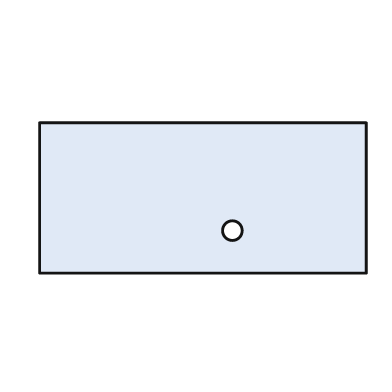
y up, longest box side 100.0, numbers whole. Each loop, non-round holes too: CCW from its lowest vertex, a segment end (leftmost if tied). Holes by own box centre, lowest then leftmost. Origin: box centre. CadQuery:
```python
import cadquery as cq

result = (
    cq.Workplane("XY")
    .moveTo(-50.0, -23.0)
    .lineTo(50.0, -23.0)
    .lineTo(50.0, 23.0)
    .lineTo(-50.0, 23.0)
    .close()
    .moveTo(9.0, -10.0)
    .circle(3.0)
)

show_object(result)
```